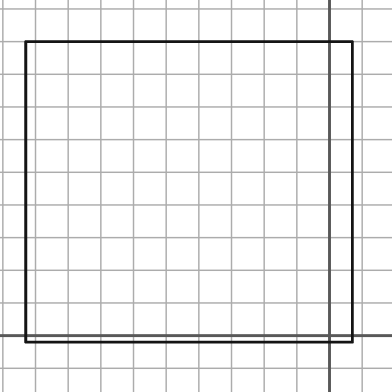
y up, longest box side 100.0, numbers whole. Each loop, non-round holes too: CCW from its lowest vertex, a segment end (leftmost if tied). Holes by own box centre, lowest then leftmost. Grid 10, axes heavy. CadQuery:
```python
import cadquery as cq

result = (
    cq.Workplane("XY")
    .moveTo(-93.0, -2.0)
    .lineTo(7.0, -2.0)
    .lineTo(7.0, 90.0)
    .lineTo(-93.0, 90.0)
    .close()
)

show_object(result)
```